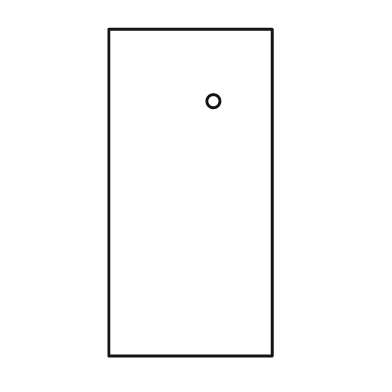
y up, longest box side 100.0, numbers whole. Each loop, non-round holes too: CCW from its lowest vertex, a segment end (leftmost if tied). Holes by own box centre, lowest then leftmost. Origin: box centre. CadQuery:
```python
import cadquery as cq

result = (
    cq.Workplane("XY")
    .moveTo(-25.0, -50.0)
    .lineTo(25.0, -50.0)
    .lineTo(25.0, 50.0)
    .lineTo(-25.0, 50.0)
    .close()
    .moveTo(7.0, 28.0)
    .circle(2.0)
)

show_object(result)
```